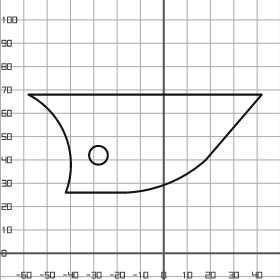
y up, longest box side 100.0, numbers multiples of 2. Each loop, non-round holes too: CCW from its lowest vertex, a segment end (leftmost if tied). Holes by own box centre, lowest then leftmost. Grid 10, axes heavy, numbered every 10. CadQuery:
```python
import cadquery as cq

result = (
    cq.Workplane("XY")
    .moveTo(-42.0, 26.0)
    .lineTo(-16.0, 26.0)
    .threePointArc((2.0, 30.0), (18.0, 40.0))
    .lineTo(42.0, 68.0)
    .lineTo(-58.0, 68.0)
    .threePointArc((-42.0, 50.0), (-42.0, 26.0))
    .close()
    .moveTo(-28.0, 42.0)
    .circle(4.0)
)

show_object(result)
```